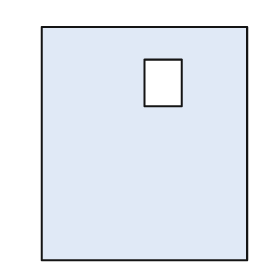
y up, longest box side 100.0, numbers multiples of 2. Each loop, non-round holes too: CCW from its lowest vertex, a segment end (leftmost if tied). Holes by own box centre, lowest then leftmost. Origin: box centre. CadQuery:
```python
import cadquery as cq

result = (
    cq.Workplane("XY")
    .moveTo(-44.0, -50.0)
    .lineTo(44.0, -50.0)
    .lineTo(44.0, 50.0)
    .lineTo(-44.0, 50.0)
    .close()
    .moveTo(0.0, 16.0)
    .lineTo(16.0, 16.0)
    .lineTo(16.0, 36.0)
    .lineTo(0.0, 36.0)
    .close()
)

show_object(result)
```